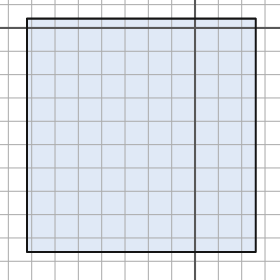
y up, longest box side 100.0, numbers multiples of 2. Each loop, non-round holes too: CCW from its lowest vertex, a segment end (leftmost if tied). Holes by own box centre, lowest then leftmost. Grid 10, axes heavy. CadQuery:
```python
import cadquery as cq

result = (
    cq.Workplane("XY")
    .moveTo(-72.0, -96.0)
    .lineTo(26.0, -96.0)
    .lineTo(26.0, 4.0)
    .lineTo(-72.0, 4.0)
    .close()
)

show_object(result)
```